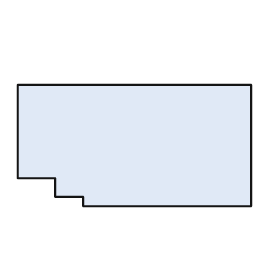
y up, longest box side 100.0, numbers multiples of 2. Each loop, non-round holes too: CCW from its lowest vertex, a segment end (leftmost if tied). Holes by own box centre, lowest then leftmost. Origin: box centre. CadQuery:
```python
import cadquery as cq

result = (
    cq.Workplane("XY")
    .moveTo(-22.0, -26.0)
    .lineTo(50.0, -26.0)
    .lineTo(50.0, 26.0)
    .lineTo(-50.0, 26.0)
    .lineTo(-50.0, -14.0)
    .lineTo(-34.0, -14.0)
    .lineTo(-34.0, -22.0)
    .lineTo(-22.0, -22.0)
    .close()
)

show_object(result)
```